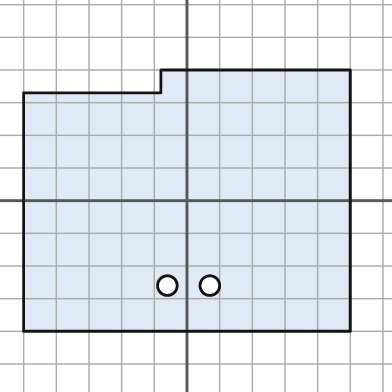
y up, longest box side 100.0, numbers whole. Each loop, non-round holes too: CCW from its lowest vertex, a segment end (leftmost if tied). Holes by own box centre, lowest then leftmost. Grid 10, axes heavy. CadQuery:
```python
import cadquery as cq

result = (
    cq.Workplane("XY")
    .moveTo(-50.0, -40.0)
    .lineTo(50.0, -40.0)
    .lineTo(50.0, 40.0)
    .lineTo(-8.0, 40.0)
    .lineTo(-8.0, 33.0)
    .lineTo(-50.0, 33.0)
    .close()
    .moveTo(-6.0, -26.0)
    .circle(3.0)
    .moveTo(7.0, -26.0)
    .circle(3.0)
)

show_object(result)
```